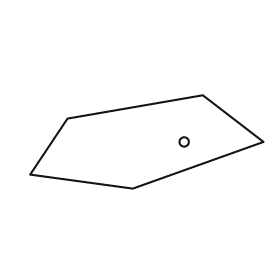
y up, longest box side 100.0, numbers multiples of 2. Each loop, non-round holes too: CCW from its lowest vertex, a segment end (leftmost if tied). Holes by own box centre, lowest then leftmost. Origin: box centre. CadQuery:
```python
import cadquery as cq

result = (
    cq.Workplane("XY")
    .moveTo(-6.0, -20.0)
    .lineTo(50.0, 0.0)
    .lineTo(24.0, 20.0)
    .lineTo(-34.0, 10.0)
    .lineTo(-50.0, -14.0)
    .close()
    .moveTo(16.0, 0.0)
    .circle(2.0)
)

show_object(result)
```